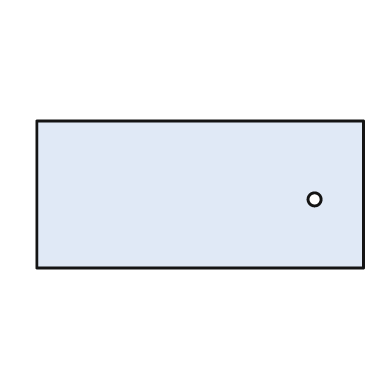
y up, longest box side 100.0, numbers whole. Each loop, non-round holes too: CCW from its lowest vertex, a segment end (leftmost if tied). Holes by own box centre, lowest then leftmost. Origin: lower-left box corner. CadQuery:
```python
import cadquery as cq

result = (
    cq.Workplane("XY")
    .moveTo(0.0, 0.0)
    .lineTo(100.0, 0.0)
    .lineTo(100.0, 45.0)
    .lineTo(0.0, 45.0)
    .close()
    .moveTo(85.0, 21.0)
    .circle(2.0)
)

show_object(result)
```